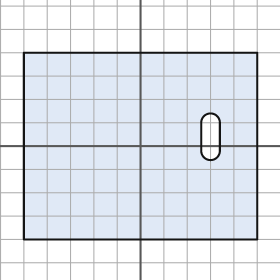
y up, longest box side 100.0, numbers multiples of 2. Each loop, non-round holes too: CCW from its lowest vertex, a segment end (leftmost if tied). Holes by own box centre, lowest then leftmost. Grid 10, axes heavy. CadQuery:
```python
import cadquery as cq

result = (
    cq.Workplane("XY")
    .moveTo(-50.0, -40.0)
    .lineTo(50.0, -40.0)
    .lineTo(50.0, 40.0)
    .lineTo(-50.0, 40.0)
    .close()
    .moveTo(26.0, -2.0)
    .threePointArc((30.0, -6.0), (34.0, -2.0))
    .lineTo(34.0, 10.0)
    .threePointArc((30.0, 14.0), (26.0, 10.0))
    .close()
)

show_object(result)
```